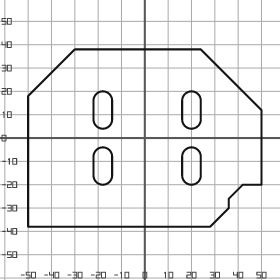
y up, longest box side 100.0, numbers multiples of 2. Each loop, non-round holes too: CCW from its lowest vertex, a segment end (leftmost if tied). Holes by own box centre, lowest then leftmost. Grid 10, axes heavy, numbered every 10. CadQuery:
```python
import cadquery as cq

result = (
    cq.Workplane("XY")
    .moveTo(-50.0, -38.0)
    .lineTo(28.0, -38.0)
    .lineTo(36.0, -30.0)
    .lineTo(36.0, -26.0)
    .lineTo(42.0, -20.0)
    .lineTo(50.0, -20.0)
    .lineTo(50.0, 12.0)
    .lineTo(24.0, 38.0)
    .lineTo(-30.0, 38.0)
    .lineTo(-50.0, 18.0)
    .close()
    .moveTo(-22.0, -16.0)
    .threePointArc((-18.0, -20.0), (-14.0, -16.0))
    .lineTo(-14.0, -8.0)
    .threePointArc((-18.0, -4.0), (-22.0, -8.0))
    .close()
    .moveTo(16.0, -16.0)
    .threePointArc((20.0, -20.0), (24.0, -16.0))
    .lineTo(24.0, -8.0)
    .threePointArc((20.0, -4.0), (16.0, -8.0))
    .close()
    .moveTo(-22.0, 8.0)
    .threePointArc((-18.0, 4.0), (-14.0, 8.0))
    .lineTo(-14.0, 16.0)
    .threePointArc((-18.0, 20.0), (-22.0, 16.0))
    .close()
    .moveTo(16.0, 8.0)
    .threePointArc((20.0, 4.0), (24.0, 8.0))
    .lineTo(24.0, 16.0)
    .threePointArc((20.0, 20.0), (16.0, 16.0))
    .close()
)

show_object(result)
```